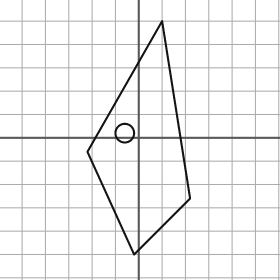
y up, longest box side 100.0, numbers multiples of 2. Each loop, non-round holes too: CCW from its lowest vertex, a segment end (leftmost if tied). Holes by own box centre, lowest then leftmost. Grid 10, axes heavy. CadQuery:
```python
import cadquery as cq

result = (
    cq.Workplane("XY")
    .moveTo(-2.0, -50.0)
    .lineTo(22.0, -26.0)
    .lineTo(10.0, 50.0)
    .lineTo(-22.0, -6.0)
    .close()
    .moveTo(-6.0, 2.0)
    .circle(4.0)
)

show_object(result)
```